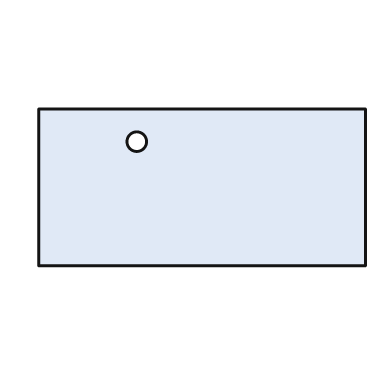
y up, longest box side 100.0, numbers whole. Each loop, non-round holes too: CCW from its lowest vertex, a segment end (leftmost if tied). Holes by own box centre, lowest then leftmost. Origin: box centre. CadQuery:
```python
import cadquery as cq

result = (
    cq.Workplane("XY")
    .moveTo(-50.0, -24.0)
    .lineTo(50.0, -24.0)
    .lineTo(50.0, 24.0)
    .lineTo(-50.0, 24.0)
    .close()
    .moveTo(-20.0, 14.0)
    .circle(3.0)
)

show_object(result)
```